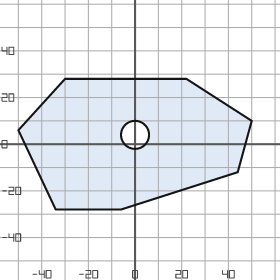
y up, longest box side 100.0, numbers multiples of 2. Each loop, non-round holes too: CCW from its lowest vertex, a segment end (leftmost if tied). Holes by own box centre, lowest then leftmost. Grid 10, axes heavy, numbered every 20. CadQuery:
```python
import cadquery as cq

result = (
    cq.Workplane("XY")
    .moveTo(-34.0, -28.0)
    .lineTo(-6.0, -28.0)
    .lineTo(44.0, -12.0)
    .lineTo(50.0, 10.0)
    .lineTo(22.0, 28.0)
    .lineTo(-30.0, 28.0)
    .lineTo(-50.0, 6.0)
    .close()
    .moveTo(0.0, 4.0)
    .circle(6.0)
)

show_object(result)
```